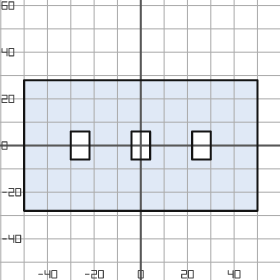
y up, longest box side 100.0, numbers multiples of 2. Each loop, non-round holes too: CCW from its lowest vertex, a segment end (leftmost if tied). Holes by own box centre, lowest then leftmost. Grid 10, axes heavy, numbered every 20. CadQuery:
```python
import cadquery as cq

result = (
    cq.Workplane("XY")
    .moveTo(-50.0, -28.0)
    .lineTo(50.0, -28.0)
    .lineTo(50.0, 28.0)
    .lineTo(-50.0, 28.0)
    .close()
    .moveTo(-30.0, -6.0)
    .lineTo(-22.0, -6.0)
    .lineTo(-22.0, 6.0)
    .lineTo(-30.0, 6.0)
    .close()
    .moveTo(-4.0, -6.0)
    .lineTo(4.0, -6.0)
    .lineTo(4.0, 6.0)
    .lineTo(-4.0, 6.0)
    .close()
    .moveTo(22.0, -6.0)
    .lineTo(30.0, -6.0)
    .lineTo(30.0, 6.0)
    .lineTo(22.0, 6.0)
    .close()
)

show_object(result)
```